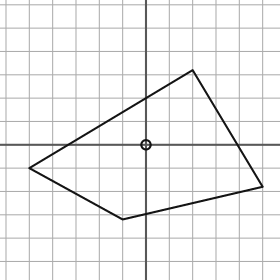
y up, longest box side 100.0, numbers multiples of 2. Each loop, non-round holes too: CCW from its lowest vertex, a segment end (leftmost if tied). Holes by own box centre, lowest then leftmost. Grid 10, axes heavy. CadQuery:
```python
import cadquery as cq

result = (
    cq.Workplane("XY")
    .moveTo(-10.0, -32.0)
    .lineTo(50.0, -18.0)
    .lineTo(20.0, 32.0)
    .lineTo(-50.0, -10.0)
    .close()
    .moveTo(0.0, 0.0)
    .circle(2.0)
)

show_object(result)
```